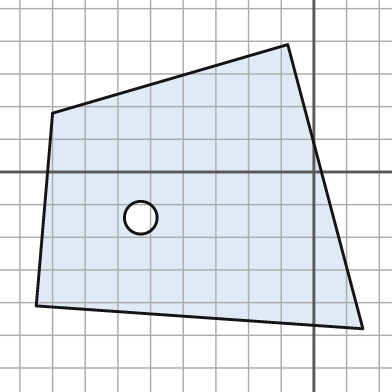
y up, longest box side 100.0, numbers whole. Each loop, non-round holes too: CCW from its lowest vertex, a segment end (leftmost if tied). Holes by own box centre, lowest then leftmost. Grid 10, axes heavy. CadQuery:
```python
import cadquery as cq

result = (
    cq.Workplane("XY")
    .moveTo(15.0, -48.0)
    .lineTo(-8.0, 39.0)
    .lineTo(-80.0, 18.0)
    .lineTo(-85.0, -41.0)
    .close()
    .moveTo(-53.0, -14.0)
    .circle(5.0)
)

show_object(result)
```